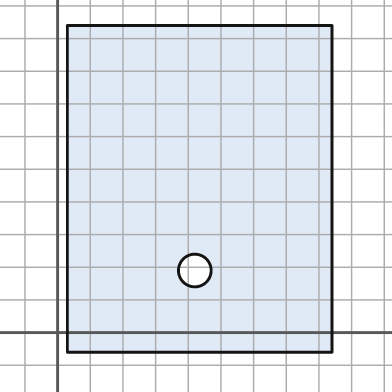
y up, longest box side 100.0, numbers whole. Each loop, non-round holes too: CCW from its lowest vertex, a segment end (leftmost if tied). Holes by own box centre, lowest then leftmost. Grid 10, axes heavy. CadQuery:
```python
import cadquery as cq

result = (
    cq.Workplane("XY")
    .moveTo(3.0, -6.0)
    .lineTo(84.0, -6.0)
    .lineTo(84.0, 94.0)
    .lineTo(3.0, 94.0)
    .close()
    .moveTo(42.0, 19.0)
    .circle(5.0)
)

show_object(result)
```